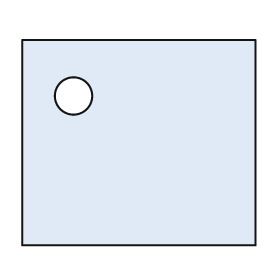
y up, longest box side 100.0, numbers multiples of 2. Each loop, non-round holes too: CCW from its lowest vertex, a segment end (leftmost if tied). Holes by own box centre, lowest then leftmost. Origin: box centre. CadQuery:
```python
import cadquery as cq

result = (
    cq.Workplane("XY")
    .moveTo(-50.0, -44.0)
    .lineTo(50.0, -44.0)
    .lineTo(50.0, 44.0)
    .lineTo(-50.0, 44.0)
    .close()
    .moveTo(-28.0, 20.0)
    .circle(8.0)
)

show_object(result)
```